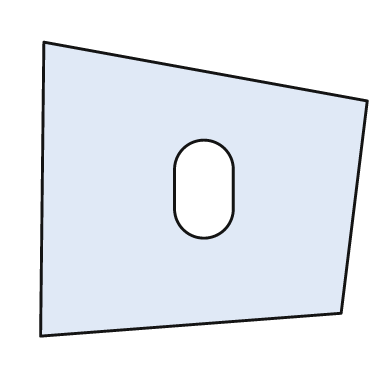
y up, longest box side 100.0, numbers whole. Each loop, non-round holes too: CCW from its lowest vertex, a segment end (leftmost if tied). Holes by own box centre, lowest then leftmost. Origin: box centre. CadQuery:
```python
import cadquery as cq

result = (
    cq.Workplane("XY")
    .moveTo(-50.0, -45.0)
    .lineTo(42.0, -38.0)
    .lineTo(50.0, 27.0)
    .lineTo(-49.0, 45.0)
    .close()
    .moveTo(-9.0, -6.0)
    .threePointArc((0.0, -15.0), (9.0, -6.0))
    .lineTo(9.0, 6.0)
    .threePointArc((0.0, 15.0), (-9.0, 6.0))
    .close()
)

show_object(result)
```